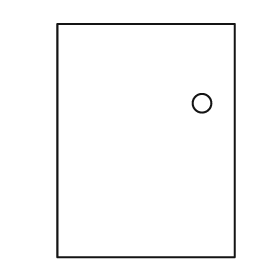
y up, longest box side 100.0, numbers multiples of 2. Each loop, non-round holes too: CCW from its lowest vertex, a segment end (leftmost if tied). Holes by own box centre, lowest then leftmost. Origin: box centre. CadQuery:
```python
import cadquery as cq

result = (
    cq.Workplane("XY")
    .moveTo(-38.0, -50.0)
    .lineTo(38.0, -50.0)
    .lineTo(38.0, 50.0)
    .lineTo(-38.0, 50.0)
    .close()
    .moveTo(24.0, 16.0)
    .circle(4.0)
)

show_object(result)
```